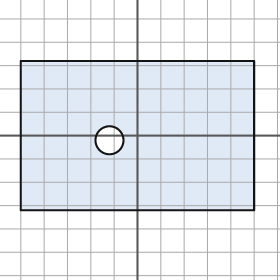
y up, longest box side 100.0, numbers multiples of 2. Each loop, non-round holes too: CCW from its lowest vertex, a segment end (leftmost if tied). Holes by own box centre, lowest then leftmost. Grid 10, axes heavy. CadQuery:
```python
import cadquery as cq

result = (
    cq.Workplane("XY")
    .moveTo(-50.0, -32.0)
    .lineTo(50.0, -32.0)
    .lineTo(50.0, 32.0)
    .lineTo(-50.0, 32.0)
    .close()
    .moveTo(-12.0, -2.0)
    .circle(6.0)
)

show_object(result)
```